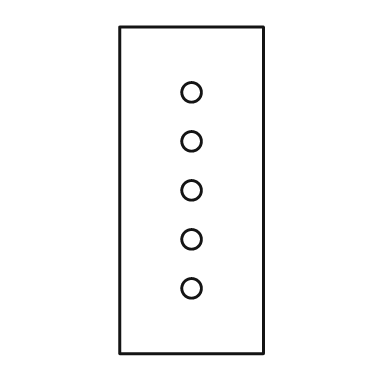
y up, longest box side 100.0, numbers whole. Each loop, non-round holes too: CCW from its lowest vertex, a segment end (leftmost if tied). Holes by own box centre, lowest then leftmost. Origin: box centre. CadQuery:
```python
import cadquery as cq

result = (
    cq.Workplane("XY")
    .moveTo(-22.0, -50.0)
    .lineTo(22.0, -50.0)
    .lineTo(22.0, 50.0)
    .lineTo(-22.0, 50.0)
    .close()
    .moveTo(0.0, -30.0)
    .circle(3.0)
    .moveTo(0.0, -15.0)
    .circle(3.0)
    .moveTo(0.0, 0.0)
    .circle(3.0)
    .moveTo(0.0, 15.0)
    .circle(3.0)
    .moveTo(0.0, 30.0)
    .circle(3.0)
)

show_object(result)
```